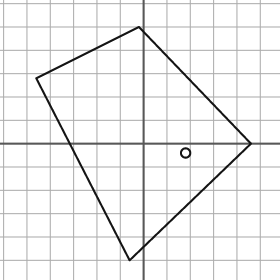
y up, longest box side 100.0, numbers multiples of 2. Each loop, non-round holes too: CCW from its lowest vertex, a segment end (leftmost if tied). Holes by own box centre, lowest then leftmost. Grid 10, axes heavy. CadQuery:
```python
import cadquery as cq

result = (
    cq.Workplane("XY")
    .moveTo(-6.0, -50.0)
    .lineTo(46.0, 0.0)
    .lineTo(-2.0, 50.0)
    .lineTo(-46.0, 28.0)
    .close()
    .moveTo(18.0, -4.0)
    .circle(2.0)
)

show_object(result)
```